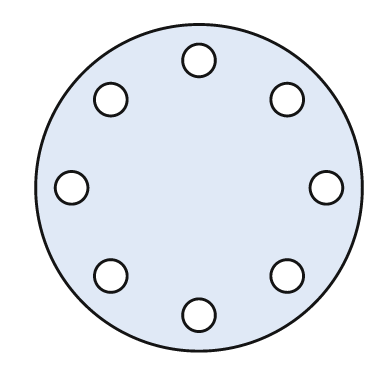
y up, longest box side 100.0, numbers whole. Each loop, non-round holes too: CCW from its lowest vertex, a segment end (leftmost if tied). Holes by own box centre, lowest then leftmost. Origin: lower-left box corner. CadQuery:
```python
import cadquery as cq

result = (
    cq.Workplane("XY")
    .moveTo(50.0, 50.0)
    .circle(50.0)
    .moveTo(50.0, 11.0)
    .circle(5.0)
    .moveTo(23.0, 23.0)
    .circle(5.0)
    .moveTo(77.0, 23.0)
    .circle(5.0)
    .moveTo(11.0, 50.0)
    .circle(5.0)
    .moveTo(89.0, 50.0)
    .circle(5.0)
    .moveTo(23.0, 77.0)
    .circle(5.0)
    .moveTo(77.0, 77.0)
    .circle(5.0)
    .moveTo(50.0, 89.0)
    .circle(5.0)
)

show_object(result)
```